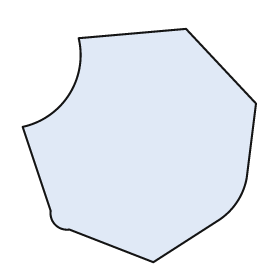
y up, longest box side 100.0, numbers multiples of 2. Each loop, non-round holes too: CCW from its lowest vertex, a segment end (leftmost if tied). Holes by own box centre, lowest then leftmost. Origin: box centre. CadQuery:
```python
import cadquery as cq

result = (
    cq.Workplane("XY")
    .moveTo(6.0, -50.0)
    .lineTo(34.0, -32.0)
    .threePointArc((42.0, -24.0), (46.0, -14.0))
    .lineTo(50.0, 18.0)
    .lineTo(20.0, 50.0)
    .lineTo(-26.0, 46.0)
    .threePointArc((-30.0, 22.0), (-50.0, 8.0))
    .lineTo(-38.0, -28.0)
    .threePointArc((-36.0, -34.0), (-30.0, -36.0))
    .close()
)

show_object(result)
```